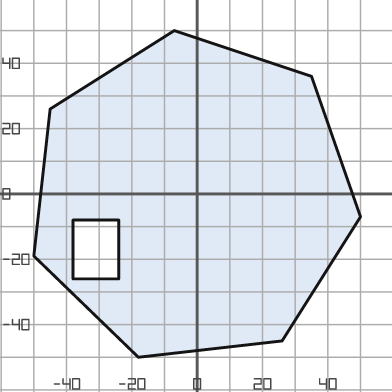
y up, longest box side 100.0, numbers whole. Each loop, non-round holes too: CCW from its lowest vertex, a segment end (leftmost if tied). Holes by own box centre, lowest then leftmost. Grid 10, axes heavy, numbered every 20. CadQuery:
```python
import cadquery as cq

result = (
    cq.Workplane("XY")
    .moveTo(-18.0, -50.0)
    .lineTo(26.0, -45.0)
    .lineTo(50.0, -7.0)
    .lineTo(35.0, 36.0)
    .lineTo(-7.0, 50.0)
    .lineTo(-45.0, 26.0)
    .lineTo(-50.0, -19.0)
    .close()
    .moveTo(-38.0, -26.0)
    .lineTo(-24.0, -26.0)
    .lineTo(-24.0, -8.0)
    .lineTo(-38.0, -8.0)
    .close()
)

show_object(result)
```